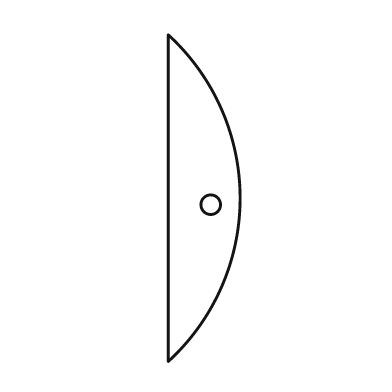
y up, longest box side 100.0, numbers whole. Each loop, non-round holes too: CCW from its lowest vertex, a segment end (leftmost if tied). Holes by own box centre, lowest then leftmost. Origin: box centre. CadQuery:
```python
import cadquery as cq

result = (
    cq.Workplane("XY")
    .moveTo(-11.0, -50.0)
    .threePointArc((11.0, 0.0), (-11.0, 50.0))
    .close()
    .moveTo(2.0, -2.0)
    .circle(3.0)
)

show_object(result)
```